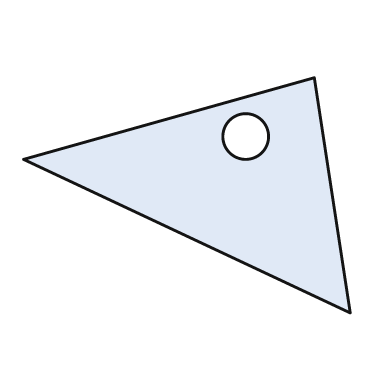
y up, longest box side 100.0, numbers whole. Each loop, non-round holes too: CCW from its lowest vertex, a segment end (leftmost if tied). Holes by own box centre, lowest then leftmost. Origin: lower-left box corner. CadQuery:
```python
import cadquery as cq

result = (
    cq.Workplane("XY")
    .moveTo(100.0, 0.0)
    .lineTo(89.0, 72.0)
    .lineTo(0.0, 47.0)
    .close()
    .moveTo(68.0, 54.0)
    .circle(7.0)
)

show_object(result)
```